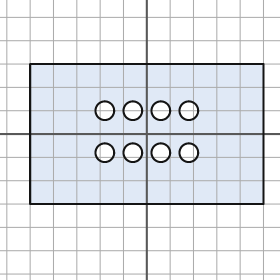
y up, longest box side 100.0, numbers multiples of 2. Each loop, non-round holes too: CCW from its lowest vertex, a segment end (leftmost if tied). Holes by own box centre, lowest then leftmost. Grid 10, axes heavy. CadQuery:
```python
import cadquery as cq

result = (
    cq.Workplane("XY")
    .moveTo(-50.0, -30.0)
    .lineTo(50.0, -30.0)
    .lineTo(50.0, 30.0)
    .lineTo(-50.0, 30.0)
    .close()
    .moveTo(-18.0, -8.0)
    .circle(4.0)
    .moveTo(-6.0, -8.0)
    .circle(4.0)
    .moveTo(6.0, -8.0)
    .circle(4.0)
    .moveTo(18.0, -8.0)
    .circle(4.0)
    .moveTo(-18.0, 10.0)
    .circle(4.0)
    .moveTo(-6.0, 10.0)
    .circle(4.0)
    .moveTo(6.0, 10.0)
    .circle(4.0)
    .moveTo(18.0, 10.0)
    .circle(4.0)
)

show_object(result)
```